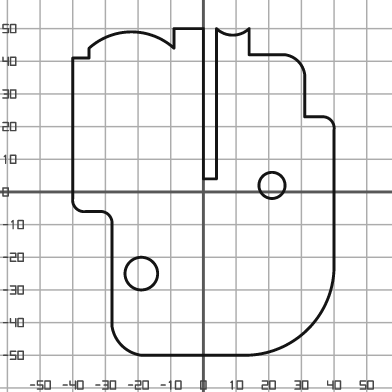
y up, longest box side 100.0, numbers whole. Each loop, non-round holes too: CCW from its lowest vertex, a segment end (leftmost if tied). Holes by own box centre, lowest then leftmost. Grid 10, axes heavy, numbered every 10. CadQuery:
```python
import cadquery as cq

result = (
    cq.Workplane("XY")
    .moveTo(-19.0, -50.0)
    .lineTo(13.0, -50.0)
    .threePointArc((32.0, -42.0), (40.0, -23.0))
    .lineTo(40.0, 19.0)
    .threePointArc((39.0, 22.0), (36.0, 23.0))
    .lineTo(31.0, 23.0)
    .lineTo(31.0, 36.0)
    .threePointArc((29.0, 40.0), (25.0, 42.0))
    .lineTo(14.0, 42.0)
    .lineTo(14.0, 50.0)
    .threePointArc((9.0, 48.0), (4.0, 50.0))
    .lineTo(4.0, 4.0)
    .lineTo(0.0, 4.0)
    .lineTo(0.0, 50.0)
    .lineTo(-9.0, 50.0)
    .lineTo(-9.0, 44.0)
    .threePointArc((-22.0, 49.0), (-35.0, 44.0))
    .lineTo(-35.0, 41.0)
    .lineTo(-40.0, 41.0)
    .lineTo(-40.0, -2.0)
    .threePointArc((-39.0, -5.0), (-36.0, -6.0))
    .lineTo(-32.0, -6.0)
    .threePointArc((-29.0, -7.0), (-28.0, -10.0))
    .lineTo(-28.0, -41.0)
    .threePointArc((-25.0, -47.0), (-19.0, -50.0))
    .close()
    .moveTo(-19.0, -25.0)
    .circle(5.0)
    .moveTo(21.0, 2.0)
    .circle(4.0)
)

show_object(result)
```